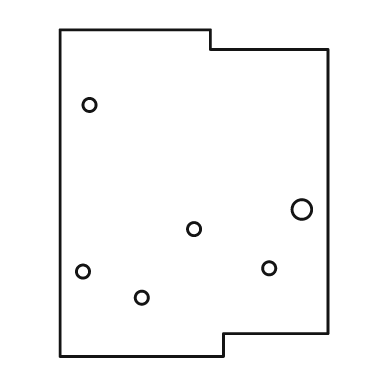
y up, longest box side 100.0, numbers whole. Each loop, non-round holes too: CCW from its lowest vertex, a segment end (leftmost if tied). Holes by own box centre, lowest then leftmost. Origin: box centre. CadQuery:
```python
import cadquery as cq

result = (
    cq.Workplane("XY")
    .moveTo(-41.0, -50.0)
    .lineTo(9.0, -50.0)
    .lineTo(9.0, -43.0)
    .lineTo(41.0, -43.0)
    .lineTo(41.0, 44.0)
    .lineTo(5.0, 44.0)
    .lineTo(5.0, 50.0)
    .lineTo(-41.0, 50.0)
    .close()
    .moveTo(-16.0, -32.0)
    .circle(2.0)
    .moveTo(-34.0, -24.0)
    .circle(2.0)
    .moveTo(23.0, -23.0)
    .circle(2.0)
    .moveTo(0.0, -11.0)
    .circle(2.0)
    .moveTo(33.0, -5.0)
    .circle(3.0)
    .moveTo(-32.0, 27.0)
    .circle(2.0)
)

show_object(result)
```